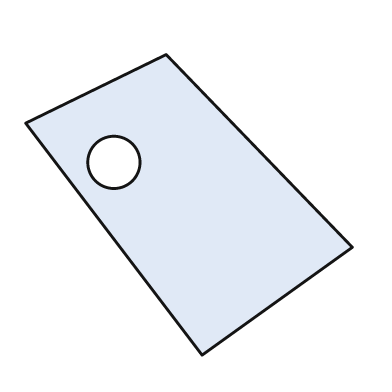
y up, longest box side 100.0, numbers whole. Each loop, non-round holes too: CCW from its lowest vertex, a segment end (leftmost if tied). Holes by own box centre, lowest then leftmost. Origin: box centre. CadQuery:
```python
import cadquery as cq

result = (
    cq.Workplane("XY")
    .moveTo(4.0, -46.0)
    .lineTo(50.0, -13.0)
    .lineTo(-7.0, 46.0)
    .lineTo(-50.0, 25.0)
    .close()
    .moveTo(-23.0, 13.0)
    .circle(8.0)
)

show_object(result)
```